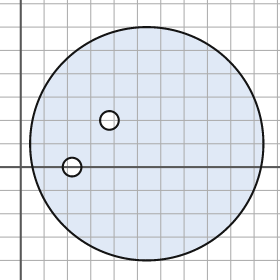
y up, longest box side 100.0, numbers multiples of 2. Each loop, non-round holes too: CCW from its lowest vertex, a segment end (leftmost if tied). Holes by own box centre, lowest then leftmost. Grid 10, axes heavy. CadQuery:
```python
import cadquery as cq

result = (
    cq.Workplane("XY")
    .moveTo(54.0, 10.0)
    .circle(50.0)
    .moveTo(22.0, 0.0)
    .circle(4.0)
    .moveTo(38.0, 20.0)
    .circle(4.0)
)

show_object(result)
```